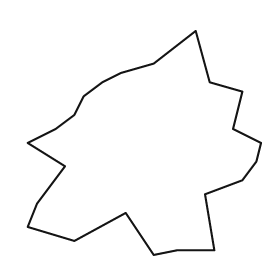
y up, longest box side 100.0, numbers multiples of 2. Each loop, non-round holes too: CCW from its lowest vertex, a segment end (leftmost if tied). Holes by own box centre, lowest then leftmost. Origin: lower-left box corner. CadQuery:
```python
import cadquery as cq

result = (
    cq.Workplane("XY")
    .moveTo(54.0, 0.0)
    .lineTo(64.0, 2.0)
    .lineTo(80.0, 2.0)
    .lineTo(76.0, 26.0)
    .lineTo(92.0, 32.0)
    .lineTo(98.0, 40.0)
    .lineTo(100.0, 48.0)
    .lineTo(88.0, 54.0)
    .lineTo(92.0, 70.0)
    .lineTo(78.0, 74.0)
    .lineTo(72.0, 96.0)
    .lineTo(54.0, 82.0)
    .lineTo(40.0, 78.0)
    .lineTo(32.0, 74.0)
    .lineTo(24.0, 68.0)
    .lineTo(20.0, 60.0)
    .lineTo(12.0, 54.0)
    .lineTo(0.0, 48.0)
    .lineTo(16.0, 38.0)
    .lineTo(4.0, 22.0)
    .lineTo(0.0, 12.0)
    .lineTo(20.0, 6.0)
    .lineTo(42.0, 18.0)
    .close()
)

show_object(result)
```